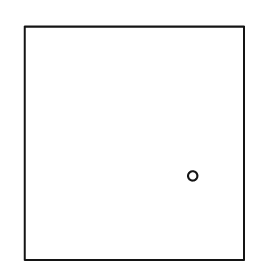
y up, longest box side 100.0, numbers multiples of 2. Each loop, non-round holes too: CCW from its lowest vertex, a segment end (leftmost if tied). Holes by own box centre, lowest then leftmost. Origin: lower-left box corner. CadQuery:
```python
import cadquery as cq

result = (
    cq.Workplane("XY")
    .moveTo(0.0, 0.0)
    .lineTo(94.0, 0.0)
    .lineTo(94.0, 100.0)
    .lineTo(0.0, 100.0)
    .close()
    .moveTo(72.0, 36.0)
    .circle(2.0)
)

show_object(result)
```